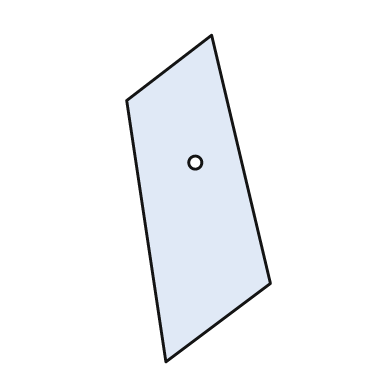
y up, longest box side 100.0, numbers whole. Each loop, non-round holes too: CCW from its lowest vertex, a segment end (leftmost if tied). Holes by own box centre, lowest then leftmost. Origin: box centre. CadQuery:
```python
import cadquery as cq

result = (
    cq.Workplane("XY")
    .moveTo(-10.0, -50.0)
    .lineTo(22.0, -26.0)
    .lineTo(4.0, 50.0)
    .lineTo(-22.0, 30.0)
    .close()
    .moveTo(-1.0, 11.0)
    .circle(2.0)
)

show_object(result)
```